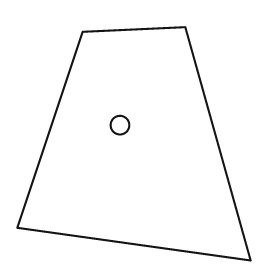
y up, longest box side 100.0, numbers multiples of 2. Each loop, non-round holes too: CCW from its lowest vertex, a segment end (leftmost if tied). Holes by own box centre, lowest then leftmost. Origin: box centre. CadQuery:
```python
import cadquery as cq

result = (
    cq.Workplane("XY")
    .moveTo(50.0, -50.0)
    .lineTo(22.0, 50.0)
    .lineTo(-22.0, 48.0)
    .lineTo(-50.0, -36.0)
    .close()
    .moveTo(-6.0, 8.0)
    .circle(4.0)
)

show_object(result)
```